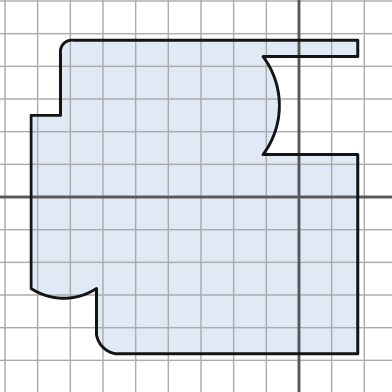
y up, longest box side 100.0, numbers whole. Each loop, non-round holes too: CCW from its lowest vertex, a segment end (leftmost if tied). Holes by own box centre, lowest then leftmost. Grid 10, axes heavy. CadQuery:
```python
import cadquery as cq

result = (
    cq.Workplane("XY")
    .moveTo(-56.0, -48.0)
    .lineTo(18.0, -48.0)
    .lineTo(18.0, 13.0)
    .lineTo(-11.0, 13.0)
    .threePointArc((-6.0, 28.0), (-11.0, 43.0))
    .lineTo(18.0, 43.0)
    .lineTo(18.0, 48.0)
    .lineTo(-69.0, 48.0)
    .threePointArc((-72.0, 47.0), (-73.0, 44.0))
    .lineTo(-73.0, 25.0)
    .lineTo(-82.0, 25.0)
    .lineTo(-82.0, -28.0)
    .threePointArc((-72.0, -31.0), (-62.0, -28.0))
    .lineTo(-62.0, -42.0)
    .threePointArc((-60.0, -46.0), (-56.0, -48.0))
    .close()
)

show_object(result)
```